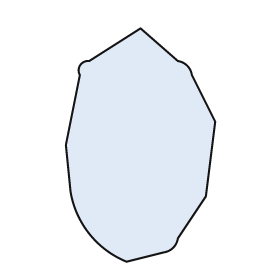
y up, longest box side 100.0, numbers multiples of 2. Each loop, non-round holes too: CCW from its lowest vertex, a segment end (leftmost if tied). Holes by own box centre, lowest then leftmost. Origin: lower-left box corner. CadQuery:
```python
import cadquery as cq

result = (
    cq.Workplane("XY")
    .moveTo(26.0, 0.0)
    .lineTo(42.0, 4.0)
    .threePointArc((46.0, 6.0), (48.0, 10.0))
    .lineTo(60.0, 28.0)
    .lineTo(64.0, 60.0)
    .lineTo(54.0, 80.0)
    .threePointArc((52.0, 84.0), (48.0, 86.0))
    .lineTo(32.0, 100.0)
    .lineTo(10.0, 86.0)
    .threePointArc((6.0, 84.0), (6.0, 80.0))
    .lineTo(0.0, 50.0)
    .lineTo(2.0, 30.0)
    .threePointArc((10.0, 12.0), (26.0, 0.0))
    .close()
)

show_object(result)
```